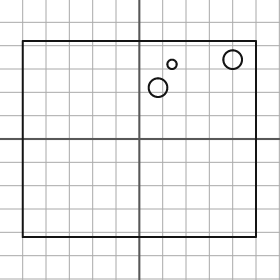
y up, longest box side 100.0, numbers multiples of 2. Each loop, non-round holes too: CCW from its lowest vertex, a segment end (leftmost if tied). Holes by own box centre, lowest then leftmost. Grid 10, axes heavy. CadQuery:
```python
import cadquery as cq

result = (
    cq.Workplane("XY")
    .moveTo(-50.0, -42.0)
    .lineTo(50.0, -42.0)
    .lineTo(50.0, 42.0)
    .lineTo(-50.0, 42.0)
    .close()
    .moveTo(8.0, 22.0)
    .circle(4.0)
    .moveTo(14.0, 32.0)
    .circle(2.0)
    .moveTo(40.0, 34.0)
    .circle(4.0)
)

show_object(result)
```